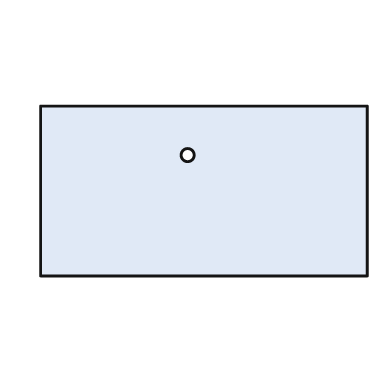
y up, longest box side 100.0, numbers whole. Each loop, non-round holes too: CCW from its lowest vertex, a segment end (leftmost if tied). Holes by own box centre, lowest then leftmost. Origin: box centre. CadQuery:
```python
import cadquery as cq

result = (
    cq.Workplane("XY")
    .moveTo(-50.0, -26.0)
    .lineTo(50.0, -26.0)
    .lineTo(50.0, 26.0)
    .lineTo(-50.0, 26.0)
    .close()
    .moveTo(-5.0, 11.0)
    .circle(2.0)
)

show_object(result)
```